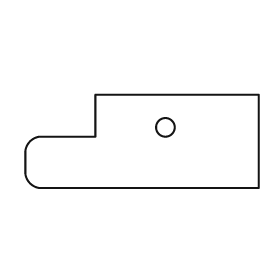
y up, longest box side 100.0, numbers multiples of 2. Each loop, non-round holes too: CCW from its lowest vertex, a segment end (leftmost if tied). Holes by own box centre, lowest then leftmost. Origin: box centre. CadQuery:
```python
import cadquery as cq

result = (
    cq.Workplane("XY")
    .moveTo(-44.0, -20.0)
    .lineTo(50.0, -20.0)
    .lineTo(50.0, 20.0)
    .lineTo(-20.0, 20.0)
    .lineTo(-20.0, 2.0)
    .lineTo(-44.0, 2.0)
    .threePointArc((-48.0, 0.0), (-50.0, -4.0))
    .lineTo(-50.0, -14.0)
    .threePointArc((-48.0, -18.0), (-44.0, -20.0))
    .close()
    .moveTo(10.0, 6.0)
    .circle(4.0)
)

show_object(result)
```